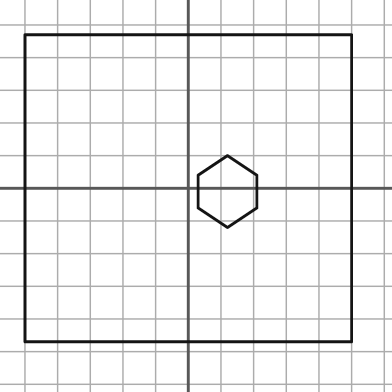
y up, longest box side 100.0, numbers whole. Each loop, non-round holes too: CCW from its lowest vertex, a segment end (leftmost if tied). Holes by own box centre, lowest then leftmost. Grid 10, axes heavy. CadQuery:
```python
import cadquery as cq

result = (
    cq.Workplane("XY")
    .moveTo(-50.0, -47.0)
    .lineTo(50.0, -47.0)
    .lineTo(50.0, 47.0)
    .lineTo(-50.0, 47.0)
    .close()
    .moveTo(12.0, -12.0)
    .lineTo(21.0, -6.0)
    .lineTo(21.0, 4.0)
    .lineTo(12.0, 10.0)
    .lineTo(3.0, 4.0)
    .lineTo(3.0, -6.0)
    .close()
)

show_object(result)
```